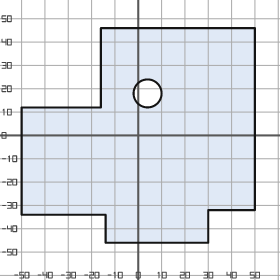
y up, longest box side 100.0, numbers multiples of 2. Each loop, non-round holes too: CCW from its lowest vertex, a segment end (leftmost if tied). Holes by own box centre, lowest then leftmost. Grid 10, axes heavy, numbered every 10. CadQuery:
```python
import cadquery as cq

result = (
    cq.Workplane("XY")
    .moveTo(-14.0, -46.0)
    .lineTo(30.0, -46.0)
    .lineTo(30.0, -32.0)
    .lineTo(50.0, -32.0)
    .lineTo(50.0, 46.0)
    .lineTo(-16.0, 46.0)
    .lineTo(-16.0, 12.0)
    .lineTo(-50.0, 12.0)
    .lineTo(-50.0, -34.0)
    .lineTo(-14.0, -34.0)
    .close()
    .moveTo(4.0, 18.0)
    .circle(6.0)
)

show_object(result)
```